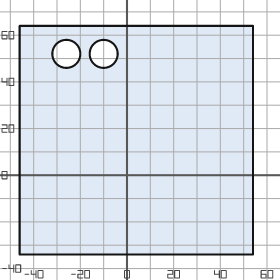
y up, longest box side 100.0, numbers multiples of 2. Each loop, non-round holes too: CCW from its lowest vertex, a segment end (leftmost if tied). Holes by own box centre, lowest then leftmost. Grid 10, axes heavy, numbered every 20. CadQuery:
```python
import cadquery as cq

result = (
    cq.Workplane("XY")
    .moveTo(-46.0, -34.0)
    .lineTo(54.0, -34.0)
    .lineTo(54.0, 64.0)
    .lineTo(-46.0, 64.0)
    .close()
    .moveTo(-26.0, 52.0)
    .circle(6.0)
    .moveTo(-10.0, 52.0)
    .circle(6.0)
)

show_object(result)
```